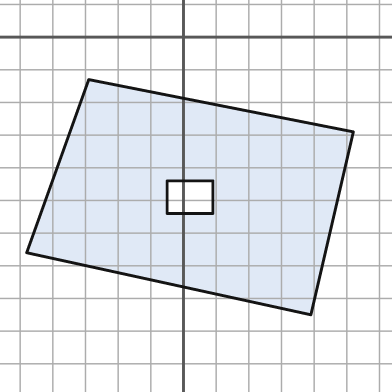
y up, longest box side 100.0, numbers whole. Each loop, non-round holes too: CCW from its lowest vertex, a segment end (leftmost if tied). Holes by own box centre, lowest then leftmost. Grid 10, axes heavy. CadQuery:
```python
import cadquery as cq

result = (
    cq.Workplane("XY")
    .moveTo(39.0, -85.0)
    .lineTo(52.0, -29.0)
    .lineTo(-29.0, -13.0)
    .lineTo(-48.0, -66.0)
    .close()
    .moveTo(-5.0, -54.0)
    .lineTo(9.0, -54.0)
    .lineTo(9.0, -44.0)
    .lineTo(-5.0, -44.0)
    .close()
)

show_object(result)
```